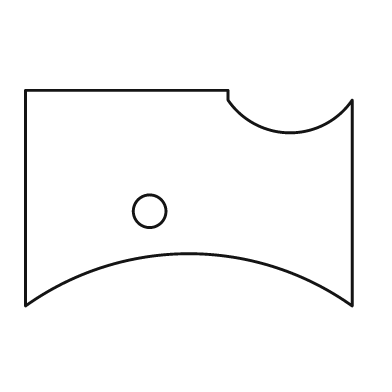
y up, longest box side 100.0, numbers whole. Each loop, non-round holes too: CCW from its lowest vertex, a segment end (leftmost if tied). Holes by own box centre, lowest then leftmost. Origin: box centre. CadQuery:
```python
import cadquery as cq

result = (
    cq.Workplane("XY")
    .moveTo(-50.0, -33.0)
    .threePointArc((0.0, -17.0), (50.0, -33.0))
    .lineTo(50.0, 30.0)
    .threePointArc((31.0, 20.0), (12.0, 30.0))
    .lineTo(12.0, 33.0)
    .lineTo(-50.0, 33.0)
    .close()
    .moveTo(-12.0, -4.0)
    .circle(5.0)
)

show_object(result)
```